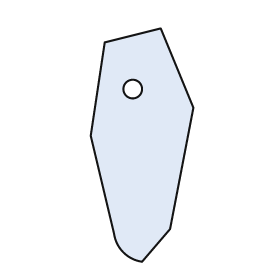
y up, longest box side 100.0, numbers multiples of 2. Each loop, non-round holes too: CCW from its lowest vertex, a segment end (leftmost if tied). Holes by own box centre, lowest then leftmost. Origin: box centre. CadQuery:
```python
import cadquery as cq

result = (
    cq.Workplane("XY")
    .moveTo(0.0, -50.0)
    .lineTo(12.0, -36.0)
    .lineTo(22.0, 16.0)
    .lineTo(8.0, 50.0)
    .lineTo(-16.0, 44.0)
    .lineTo(-22.0, 4.0)
    .lineTo(-12.0, -38.0)
    .threePointArc((-8.0, -46.0), (0.0, -50.0))
    .close()
    .moveTo(-4.0, 24.0)
    .circle(4.0)
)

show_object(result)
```